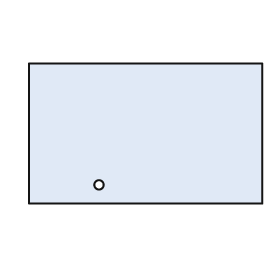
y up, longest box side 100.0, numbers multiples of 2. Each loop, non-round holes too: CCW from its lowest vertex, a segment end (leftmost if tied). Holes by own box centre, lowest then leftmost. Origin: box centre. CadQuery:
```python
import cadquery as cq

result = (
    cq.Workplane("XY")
    .moveTo(-50.0, -30.0)
    .lineTo(50.0, -30.0)
    .lineTo(50.0, 30.0)
    .lineTo(-50.0, 30.0)
    .close()
    .moveTo(-20.0, -22.0)
    .circle(2.0)
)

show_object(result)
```